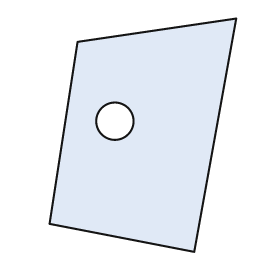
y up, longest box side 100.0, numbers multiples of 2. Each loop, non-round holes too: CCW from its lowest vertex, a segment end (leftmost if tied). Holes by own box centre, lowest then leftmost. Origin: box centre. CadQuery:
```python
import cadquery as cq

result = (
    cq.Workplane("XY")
    .moveTo(22.0, -50.0)
    .lineTo(40.0, 50.0)
    .lineTo(-28.0, 40.0)
    .lineTo(-40.0, -38.0)
    .close()
    .moveTo(-12.0, 6.0)
    .circle(8.0)
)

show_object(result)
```